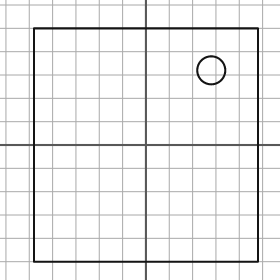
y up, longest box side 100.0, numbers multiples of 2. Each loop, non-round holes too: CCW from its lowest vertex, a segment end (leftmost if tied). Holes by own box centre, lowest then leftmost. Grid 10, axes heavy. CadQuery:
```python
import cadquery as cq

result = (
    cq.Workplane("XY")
    .moveTo(-48.0, -50.0)
    .lineTo(48.0, -50.0)
    .lineTo(48.0, 50.0)
    .lineTo(-48.0, 50.0)
    .close()
    .moveTo(28.0, 32.0)
    .circle(6.0)
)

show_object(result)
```